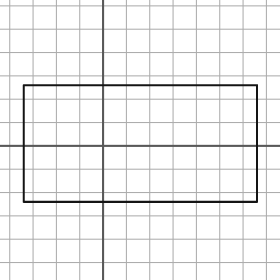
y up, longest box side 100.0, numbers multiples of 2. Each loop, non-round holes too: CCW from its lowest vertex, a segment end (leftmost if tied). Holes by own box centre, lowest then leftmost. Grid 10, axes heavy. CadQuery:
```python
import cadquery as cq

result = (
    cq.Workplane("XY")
    .moveTo(-34.0, -24.0)
    .lineTo(66.0, -24.0)
    .lineTo(66.0, 26.0)
    .lineTo(-34.0, 26.0)
    .close()
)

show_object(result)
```